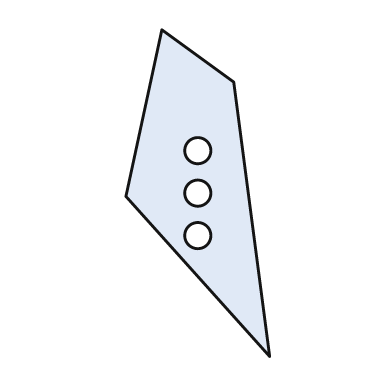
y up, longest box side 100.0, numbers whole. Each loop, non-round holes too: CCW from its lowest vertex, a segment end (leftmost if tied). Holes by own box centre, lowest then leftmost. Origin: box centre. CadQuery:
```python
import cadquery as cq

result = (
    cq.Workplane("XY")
    .moveTo(22.0, -50.0)
    .lineTo(11.0, 34.0)
    .lineTo(-11.0, 50.0)
    .lineTo(-22.0, -1.0)
    .close()
    .moveTo(0.0, -13.0)
    .circle(4.0)
    .moveTo(0.0, 0.0)
    .circle(4.0)
    .moveTo(0.0, 13.0)
    .circle(4.0)
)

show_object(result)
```